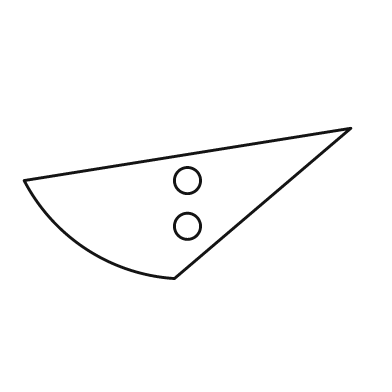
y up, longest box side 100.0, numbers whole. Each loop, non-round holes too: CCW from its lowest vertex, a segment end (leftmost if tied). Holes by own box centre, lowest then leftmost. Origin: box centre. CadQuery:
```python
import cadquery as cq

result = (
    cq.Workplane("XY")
    .moveTo(-4.0, -23.0)
    .lineTo(50.0, 23.0)
    .lineTo(-50.0, 7.0)
    .threePointArc((-31.0, -14.0), (-4.0, -23.0))
    .close()
    .moveTo(0.0, -7.0)
    .circle(4.0)
    .moveTo(0.0, 7.0)
    .circle(4.0)
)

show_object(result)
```